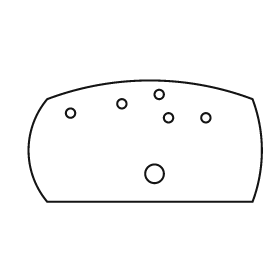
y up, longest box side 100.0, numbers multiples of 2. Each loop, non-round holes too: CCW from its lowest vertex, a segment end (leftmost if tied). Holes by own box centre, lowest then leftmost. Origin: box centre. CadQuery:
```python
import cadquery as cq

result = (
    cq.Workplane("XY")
    .moveTo(-42.0, -26.0)
    .lineTo(46.0, -26.0)
    .threePointArc((50.0, -4.0), (46.0, 18.0))
    .threePointArc((2.0, 26.0), (-42.0, 18.0))
    .threePointArc((-50.0, -4.0), (-42.0, -26.0))
    .close()
    .moveTo(4.0, -14.0)
    .circle(4.0)
    .moveTo(10.0, 10.0)
    .circle(2.0)
    .moveTo(26.0, 10.0)
    .circle(2.0)
    .moveTo(-32.0, 12.0)
    .circle(2.0)
    .moveTo(-10.0, 16.0)
    .circle(2.0)
    .moveTo(6.0, 20.0)
    .circle(2.0)
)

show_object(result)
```